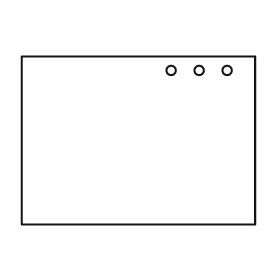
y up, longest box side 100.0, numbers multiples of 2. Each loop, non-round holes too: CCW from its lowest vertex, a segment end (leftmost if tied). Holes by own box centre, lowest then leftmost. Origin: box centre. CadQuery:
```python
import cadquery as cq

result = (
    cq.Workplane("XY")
    .moveTo(-50.0, -36.0)
    .lineTo(50.0, -36.0)
    .lineTo(50.0, 36.0)
    .lineTo(-50.0, 36.0)
    .close()
    .moveTo(14.0, 30.0)
    .circle(2.0)
    .moveTo(26.0, 30.0)
    .circle(2.0)
    .moveTo(38.0, 30.0)
    .circle(2.0)
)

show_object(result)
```